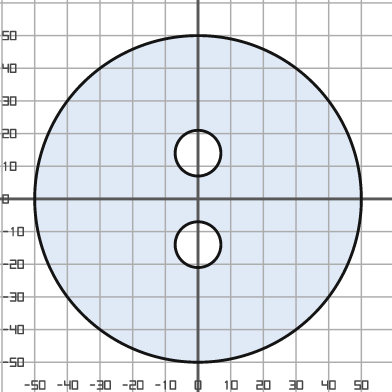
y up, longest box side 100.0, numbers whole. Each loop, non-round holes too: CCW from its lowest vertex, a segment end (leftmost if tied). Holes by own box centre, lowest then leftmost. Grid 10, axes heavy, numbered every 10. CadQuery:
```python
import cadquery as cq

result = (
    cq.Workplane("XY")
    .moveTo(0.0, 0.0)
    .circle(50.0)
    .moveTo(0.0, -14.0)
    .circle(7.0)
    .moveTo(0.0, 14.0)
    .circle(7.0)
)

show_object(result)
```